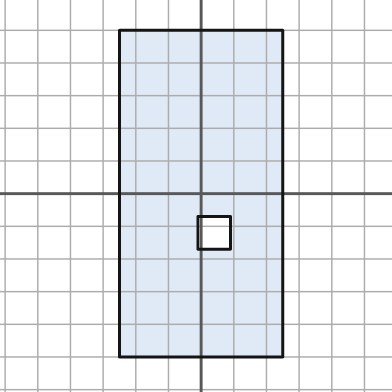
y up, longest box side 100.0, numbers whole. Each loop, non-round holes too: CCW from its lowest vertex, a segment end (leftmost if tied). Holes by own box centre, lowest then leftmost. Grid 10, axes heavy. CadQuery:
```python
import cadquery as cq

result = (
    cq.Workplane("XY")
    .moveTo(-25.0, -50.0)
    .lineTo(25.0, -50.0)
    .lineTo(25.0, 50.0)
    .lineTo(-25.0, 50.0)
    .close()
    .moveTo(-1.0, -17.0)
    .lineTo(9.0, -17.0)
    .lineTo(9.0, -7.0)
    .lineTo(-1.0, -7.0)
    .close()
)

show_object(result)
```